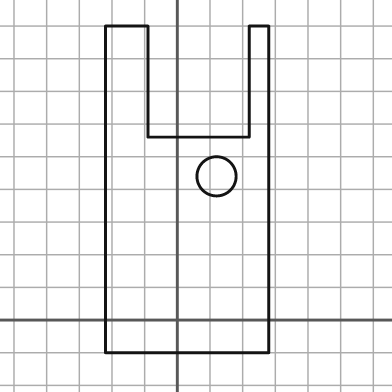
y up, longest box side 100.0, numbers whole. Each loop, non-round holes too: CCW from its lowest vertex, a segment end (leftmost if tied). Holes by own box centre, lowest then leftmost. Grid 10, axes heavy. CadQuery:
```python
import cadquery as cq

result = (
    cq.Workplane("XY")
    .moveTo(-22.0, -10.0)
    .lineTo(28.0, -10.0)
    .lineTo(28.0, 90.0)
    .lineTo(22.0, 90.0)
    .lineTo(22.0, 56.0)
    .lineTo(-9.0, 56.0)
    .lineTo(-9.0, 90.0)
    .lineTo(-22.0, 90.0)
    .close()
    .moveTo(12.0, 44.0)
    .circle(6.0)
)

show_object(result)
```